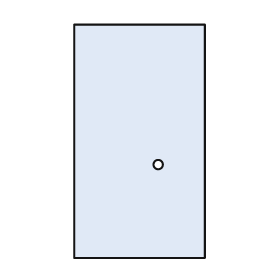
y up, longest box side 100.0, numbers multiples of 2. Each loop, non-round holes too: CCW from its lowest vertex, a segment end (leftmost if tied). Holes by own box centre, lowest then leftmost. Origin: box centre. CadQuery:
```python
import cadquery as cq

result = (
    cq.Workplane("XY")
    .moveTo(-28.0, -50.0)
    .lineTo(28.0, -50.0)
    .lineTo(28.0, 50.0)
    .lineTo(-28.0, 50.0)
    .close()
    .moveTo(8.0, -10.0)
    .circle(2.0)
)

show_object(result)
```